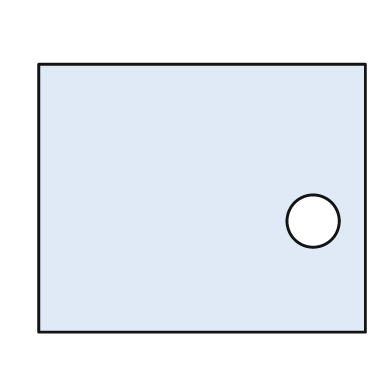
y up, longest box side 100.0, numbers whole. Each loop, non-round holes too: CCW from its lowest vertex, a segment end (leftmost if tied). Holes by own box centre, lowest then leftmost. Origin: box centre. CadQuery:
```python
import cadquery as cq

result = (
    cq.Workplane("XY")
    .moveTo(-50.0, -41.0)
    .lineTo(50.0, -41.0)
    .lineTo(50.0, 41.0)
    .lineTo(-50.0, 41.0)
    .close()
    .moveTo(34.0, -7.0)
    .circle(8.0)
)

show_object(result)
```